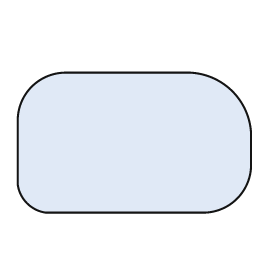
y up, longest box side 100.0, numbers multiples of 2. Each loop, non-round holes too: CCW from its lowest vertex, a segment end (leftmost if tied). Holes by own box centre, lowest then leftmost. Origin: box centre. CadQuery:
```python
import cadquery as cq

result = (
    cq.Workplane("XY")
    .moveTo(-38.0, -30.0)
    .lineTo(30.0, -30.0)
    .threePointArc((44.0, -24.0), (50.0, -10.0))
    .lineTo(50.0, 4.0)
    .threePointArc((42.0, 22.0), (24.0, 30.0))
    .lineTo(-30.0, 30.0)
    .threePointArc((-44.0, 24.0), (-50.0, 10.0))
    .lineTo(-50.0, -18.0)
    .threePointArc((-46.0, -26.0), (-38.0, -30.0))
    .close()
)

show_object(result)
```